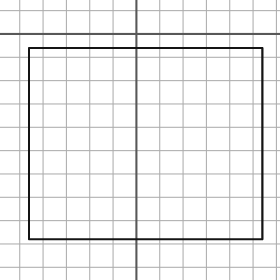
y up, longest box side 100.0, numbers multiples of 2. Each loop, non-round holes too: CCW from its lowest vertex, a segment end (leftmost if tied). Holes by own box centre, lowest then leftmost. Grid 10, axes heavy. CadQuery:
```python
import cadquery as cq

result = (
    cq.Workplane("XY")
    .moveTo(-46.0, -88.0)
    .lineTo(54.0, -88.0)
    .lineTo(54.0, -6.0)
    .lineTo(-46.0, -6.0)
    .close()
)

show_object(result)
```